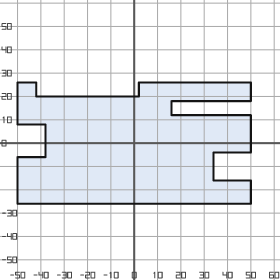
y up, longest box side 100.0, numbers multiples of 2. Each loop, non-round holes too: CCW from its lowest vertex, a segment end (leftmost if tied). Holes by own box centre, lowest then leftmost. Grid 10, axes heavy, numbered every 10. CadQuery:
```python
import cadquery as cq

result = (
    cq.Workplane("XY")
    .moveTo(-50.0, -26.0)
    .lineTo(50.0, -26.0)
    .lineTo(50.0, -16.0)
    .lineTo(34.0, -16.0)
    .lineTo(34.0, -4.0)
    .lineTo(50.0, -4.0)
    .lineTo(50.0, 12.0)
    .lineTo(16.0, 12.0)
    .lineTo(16.0, 18.0)
    .lineTo(50.0, 18.0)
    .lineTo(50.0, 26.0)
    .lineTo(2.0, 26.0)
    .lineTo(2.0, 20.0)
    .lineTo(-42.0, 20.0)
    .lineTo(-42.0, 26.0)
    .lineTo(-50.0, 26.0)
    .lineTo(-50.0, 8.0)
    .lineTo(-38.0, 8.0)
    .lineTo(-38.0, -6.0)
    .lineTo(-50.0, -6.0)
    .close()
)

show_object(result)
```